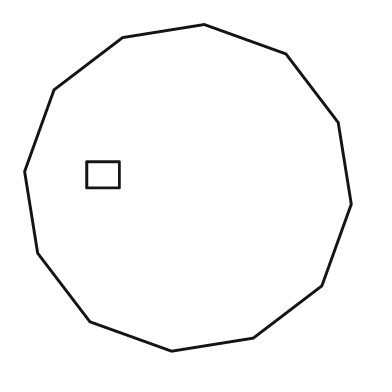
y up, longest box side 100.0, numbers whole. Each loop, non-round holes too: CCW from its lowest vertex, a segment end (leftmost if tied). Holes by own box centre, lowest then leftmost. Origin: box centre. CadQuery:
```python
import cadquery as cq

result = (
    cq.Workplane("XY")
    .moveTo(-5.0, -50.0)
    .lineTo(20.0, -46.0)
    .lineTo(41.0, -30.0)
    .lineTo(50.0, -5.0)
    .lineTo(46.0, 20.0)
    .lineTo(30.0, 41.0)
    .lineTo(5.0, 50.0)
    .lineTo(-20.0, 46.0)
    .lineTo(-41.0, 30.0)
    .lineTo(-50.0, 5.0)
    .lineTo(-46.0, -20.0)
    .lineTo(-30.0, -41.0)
    .close()
    .moveTo(-31.0, 0.0)
    .lineTo(-21.0, 0.0)
    .lineTo(-21.0, 8.0)
    .lineTo(-31.0, 8.0)
    .close()
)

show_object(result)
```